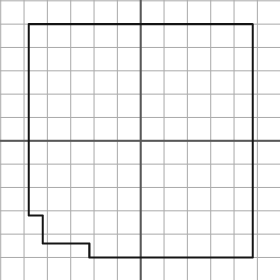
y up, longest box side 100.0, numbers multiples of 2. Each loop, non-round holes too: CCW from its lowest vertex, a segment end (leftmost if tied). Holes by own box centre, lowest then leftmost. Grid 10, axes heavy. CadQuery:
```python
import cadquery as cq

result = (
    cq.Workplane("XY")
    .moveTo(-22.0, -50.0)
    .lineTo(48.0, -50.0)
    .lineTo(48.0, 50.0)
    .lineTo(-48.0, 50.0)
    .lineTo(-48.0, -32.0)
    .lineTo(-42.0, -32.0)
    .lineTo(-42.0, -44.0)
    .lineTo(-22.0, -44.0)
    .close()
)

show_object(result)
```